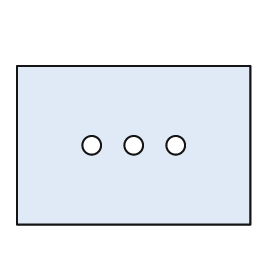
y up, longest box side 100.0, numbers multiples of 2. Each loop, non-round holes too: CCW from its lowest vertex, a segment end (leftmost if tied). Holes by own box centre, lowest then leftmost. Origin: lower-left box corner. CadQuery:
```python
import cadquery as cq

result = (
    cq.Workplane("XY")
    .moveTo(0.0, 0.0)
    .lineTo(100.0, 0.0)
    .lineTo(100.0, 68.0)
    .lineTo(0.0, 68.0)
    .close()
    .moveTo(32.0, 34.0)
    .circle(4.0)
    .moveTo(50.0, 34.0)
    .circle(4.0)
    .moveTo(68.0, 34.0)
    .circle(4.0)
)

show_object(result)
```